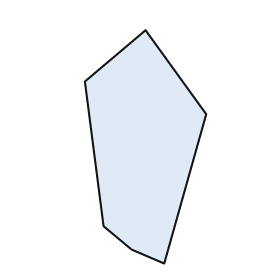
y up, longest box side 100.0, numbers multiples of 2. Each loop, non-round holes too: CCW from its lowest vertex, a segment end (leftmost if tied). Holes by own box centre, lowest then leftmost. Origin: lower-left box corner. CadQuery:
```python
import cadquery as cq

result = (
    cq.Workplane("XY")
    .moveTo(34.0, 0.0)
    .lineTo(52.0, 64.0)
    .lineTo(26.0, 100.0)
    .lineTo(0.0, 78.0)
    .lineTo(8.0, 16.0)
    .lineTo(20.0, 6.0)
    .close()
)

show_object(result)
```